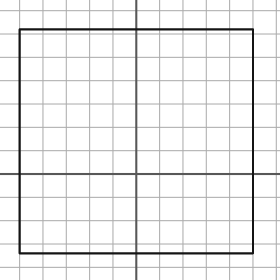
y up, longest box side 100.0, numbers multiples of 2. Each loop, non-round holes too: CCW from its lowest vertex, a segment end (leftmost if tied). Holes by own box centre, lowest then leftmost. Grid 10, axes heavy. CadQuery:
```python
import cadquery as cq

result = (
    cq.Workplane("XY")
    .moveTo(-50.0, -34.0)
    .lineTo(50.0, -34.0)
    .lineTo(50.0, 62.0)
    .lineTo(-50.0, 62.0)
    .close()
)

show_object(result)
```